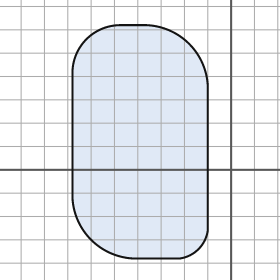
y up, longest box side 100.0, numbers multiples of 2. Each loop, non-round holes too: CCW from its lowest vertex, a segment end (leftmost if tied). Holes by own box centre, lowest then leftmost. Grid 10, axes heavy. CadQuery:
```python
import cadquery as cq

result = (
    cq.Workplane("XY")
    .moveTo(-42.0, -38.0)
    .lineTo(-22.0, -38.0)
    .threePointArc((-14.0, -34.0), (-10.0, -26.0))
    .lineTo(-10.0, 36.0)
    .threePointArc((-18.0, 54.0), (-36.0, 62.0))
    .lineTo(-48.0, 62.0)
    .threePointArc((-62.0, 56.0), (-68.0, 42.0))
    .lineTo(-68.0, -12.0)
    .threePointArc((-60.0, -30.0), (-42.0, -38.0))
    .close()
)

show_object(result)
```